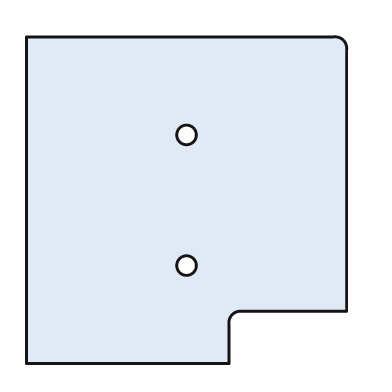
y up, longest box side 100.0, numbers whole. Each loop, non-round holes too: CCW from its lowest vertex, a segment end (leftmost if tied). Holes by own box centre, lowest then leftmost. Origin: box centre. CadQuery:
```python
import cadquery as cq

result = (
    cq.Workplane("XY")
    .moveTo(-49.0, -50.0)
    .lineTo(13.0, -50.0)
    .lineTo(13.0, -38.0)
    .threePointArc((14.0, -35.0), (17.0, -34.0))
    .lineTo(49.0, -34.0)
    .lineTo(49.0, 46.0)
    .threePointArc((48.0, 49.0), (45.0, 50.0))
    .lineTo(-49.0, 50.0)
    .close()
    .moveTo(0.0, -20.0)
    .circle(3.0)
    .moveTo(0.0, 20.0)
    .circle(3.0)
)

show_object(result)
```